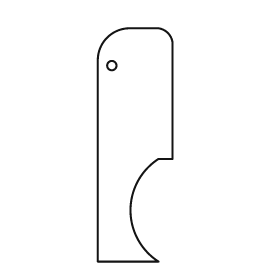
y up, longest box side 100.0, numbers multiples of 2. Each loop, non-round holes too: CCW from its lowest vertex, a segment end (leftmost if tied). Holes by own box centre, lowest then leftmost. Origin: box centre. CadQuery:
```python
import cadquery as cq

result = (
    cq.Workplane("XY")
    .moveTo(-16.0, -50.0)
    .lineTo(10.0, -50.0)
    .threePointArc((-2.0, -28.0), (10.0, -6.0))
    .lineTo(16.0, -6.0)
    .lineTo(16.0, 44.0)
    .threePointArc((14.0, 48.0), (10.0, 50.0))
    .lineTo(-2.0, 50.0)
    .threePointArc((-12.0, 46.0), (-16.0, 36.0))
    .close()
    .moveTo(-10.0, 34.0)
    .circle(2.0)
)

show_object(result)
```